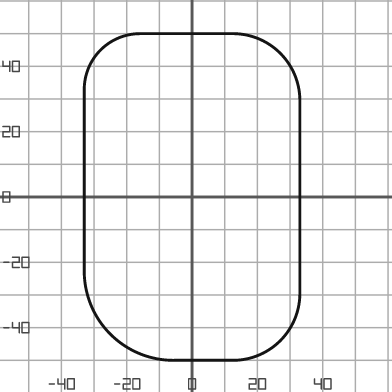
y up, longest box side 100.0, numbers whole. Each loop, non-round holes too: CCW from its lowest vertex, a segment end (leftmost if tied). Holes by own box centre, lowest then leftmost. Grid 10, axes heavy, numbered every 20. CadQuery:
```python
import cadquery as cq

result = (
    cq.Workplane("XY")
    .moveTo(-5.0, -50.0)
    .lineTo(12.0, -50.0)
    .threePointArc((27.0, -44.0), (33.0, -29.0))
    .lineTo(33.0, 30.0)
    .threePointArc((27.0, 44.0), (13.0, 50.0))
    .lineTo(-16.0, 50.0)
    .threePointArc((-28.0, 45.0), (-33.0, 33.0))
    .lineTo(-33.0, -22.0)
    .threePointArc((-25.0, -42.0), (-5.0, -50.0))
    .close()
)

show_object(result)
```